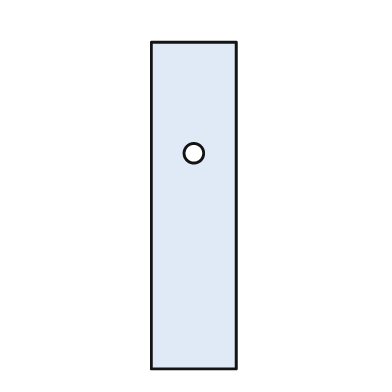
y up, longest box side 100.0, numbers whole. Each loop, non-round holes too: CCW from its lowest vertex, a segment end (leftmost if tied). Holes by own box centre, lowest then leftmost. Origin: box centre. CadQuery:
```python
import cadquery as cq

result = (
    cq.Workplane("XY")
    .moveTo(-13.0, -50.0)
    .lineTo(13.0, -50.0)
    .lineTo(13.0, 50.0)
    .lineTo(-13.0, 50.0)
    .close()
    .moveTo(0.0, 16.0)
    .circle(3.0)
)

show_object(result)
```